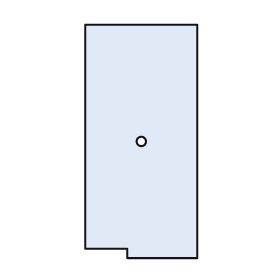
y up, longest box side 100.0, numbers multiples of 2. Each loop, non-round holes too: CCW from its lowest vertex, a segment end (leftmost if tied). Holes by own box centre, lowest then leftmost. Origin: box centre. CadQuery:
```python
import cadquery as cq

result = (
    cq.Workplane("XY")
    .moveTo(-6.0, -50.0)
    .lineTo(24.0, -50.0)
    .lineTo(24.0, 50.0)
    .lineTo(-24.0, 50.0)
    .lineTo(-24.0, -46.0)
    .lineTo(-6.0, -46.0)
    .close()
    .moveTo(0.0, 0.0)
    .circle(2.0)
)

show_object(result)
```